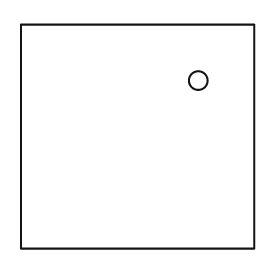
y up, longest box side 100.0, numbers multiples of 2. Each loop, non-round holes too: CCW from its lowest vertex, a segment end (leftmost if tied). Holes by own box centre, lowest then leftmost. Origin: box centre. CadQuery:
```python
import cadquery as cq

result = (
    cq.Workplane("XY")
    .moveTo(-50.0, -48.0)
    .lineTo(50.0, -48.0)
    .lineTo(50.0, 48.0)
    .lineTo(-50.0, 48.0)
    .close()
    .moveTo(26.0, 24.0)
    .circle(4.0)
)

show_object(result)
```